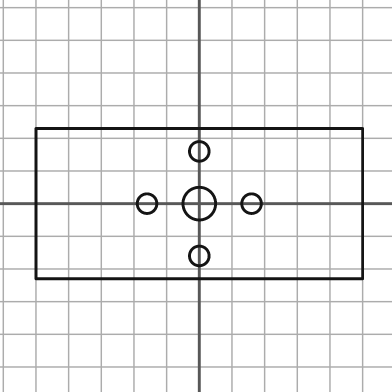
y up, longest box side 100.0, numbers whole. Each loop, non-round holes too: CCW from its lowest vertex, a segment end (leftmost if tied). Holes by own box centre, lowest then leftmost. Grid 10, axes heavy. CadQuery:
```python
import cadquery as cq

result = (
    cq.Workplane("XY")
    .moveTo(-50.0, -23.0)
    .lineTo(50.0, -23.0)
    .lineTo(50.0, 23.0)
    .lineTo(-50.0, 23.0)
    .close()
    .moveTo(0.0, -16.0)
    .circle(3.0)
    .moveTo(-16.0, 0.0)
    .circle(3.0)
    .moveTo(0.0, 0.0)
    .circle(5.0)
    .moveTo(16.0, 0.0)
    .circle(3.0)
    .moveTo(0.0, 16.0)
    .circle(3.0)
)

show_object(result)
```